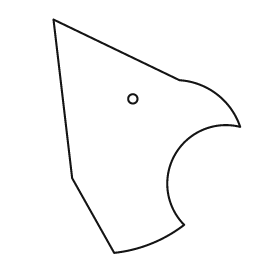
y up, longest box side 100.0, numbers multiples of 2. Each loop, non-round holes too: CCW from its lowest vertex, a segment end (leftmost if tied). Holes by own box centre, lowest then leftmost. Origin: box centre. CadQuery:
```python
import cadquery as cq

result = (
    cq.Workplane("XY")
    .moveTo(-14.0, -50.0)
    .threePointArc((2.0, -46.0), (16.0, -38.0))
    .threePointArc((12.0, -8.0), (40.0, 4.0))
    .threePointArc((30.0, 18.0), (14.0, 24.0))
    .lineTo(-40.0, 50.0)
    .lineTo(-32.0, -18.0)
    .close()
    .moveTo(-6.0, 16.0)
    .circle(2.0)
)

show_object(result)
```